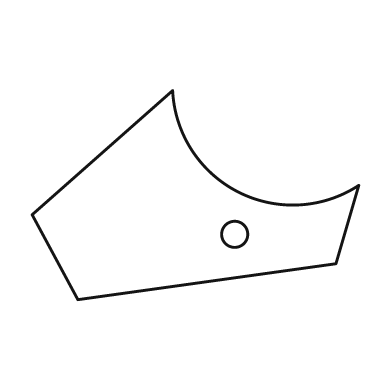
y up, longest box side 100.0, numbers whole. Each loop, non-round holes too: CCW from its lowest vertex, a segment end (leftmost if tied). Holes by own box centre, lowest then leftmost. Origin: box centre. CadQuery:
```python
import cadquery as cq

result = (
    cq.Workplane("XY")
    .moveTo(-36.0, -32.0)
    .lineTo(43.0, -21.0)
    .lineTo(50.0, 3.0)
    .threePointArc((13.0, 1.0), (-7.0, 32.0))
    .lineTo(-50.0, -6.0)
    .close()
    .moveTo(12.0, -12.0)
    .circle(4.0)
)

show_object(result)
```